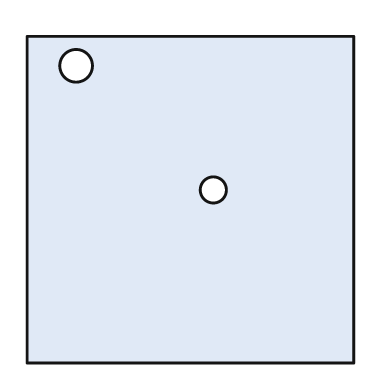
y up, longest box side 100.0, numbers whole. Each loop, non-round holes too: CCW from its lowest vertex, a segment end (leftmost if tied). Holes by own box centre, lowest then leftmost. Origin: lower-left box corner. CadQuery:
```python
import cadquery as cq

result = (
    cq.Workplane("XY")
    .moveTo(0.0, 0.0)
    .lineTo(100.0, 0.0)
    .lineTo(100.0, 100.0)
    .lineTo(0.0, 100.0)
    .close()
    .moveTo(57.0, 53.0)
    .circle(4.0)
    .moveTo(15.0, 91.0)
    .circle(5.0)
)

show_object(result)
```